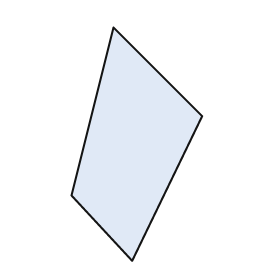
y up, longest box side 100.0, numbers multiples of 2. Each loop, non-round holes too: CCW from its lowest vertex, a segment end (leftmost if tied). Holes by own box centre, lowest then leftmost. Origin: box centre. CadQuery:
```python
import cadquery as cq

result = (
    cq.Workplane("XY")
    .moveTo(-2.0, -50.0)
    .lineTo(28.0, 12.0)
    .lineTo(-10.0, 50.0)
    .lineTo(-28.0, -22.0)
    .close()
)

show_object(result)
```